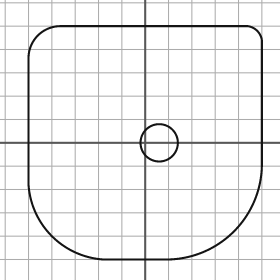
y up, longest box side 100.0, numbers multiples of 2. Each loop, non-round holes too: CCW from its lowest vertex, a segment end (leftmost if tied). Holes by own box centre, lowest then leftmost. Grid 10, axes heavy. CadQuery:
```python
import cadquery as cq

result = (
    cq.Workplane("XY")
    .moveTo(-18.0, -50.0)
    .lineTo(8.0, -50.0)
    .threePointArc((38.0, -38.0), (50.0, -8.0))
    .lineTo(50.0, 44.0)
    .threePointArc((48.0, 48.0), (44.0, 50.0))
    .lineTo(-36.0, 50.0)
    .threePointArc((-46.0, 46.0), (-50.0, 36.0))
    .lineTo(-50.0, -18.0)
    .threePointArc((-40.0, -40.0), (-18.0, -50.0))
    .close()
    .moveTo(6.0, 0.0)
    .circle(8.0)
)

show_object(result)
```